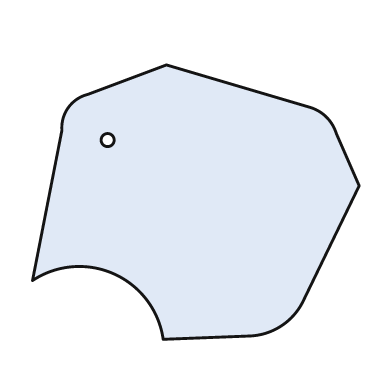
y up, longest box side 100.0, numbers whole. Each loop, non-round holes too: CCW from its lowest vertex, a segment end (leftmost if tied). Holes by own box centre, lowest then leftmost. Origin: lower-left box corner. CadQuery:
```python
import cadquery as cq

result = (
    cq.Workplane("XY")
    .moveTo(40.0, 0.0)
    .lineTo(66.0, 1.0)
    .threePointArc((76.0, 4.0), (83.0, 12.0))
    .lineTo(100.0, 47.0)
    .lineTo(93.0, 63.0)
    .threePointArc((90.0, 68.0), (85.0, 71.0))
    .lineTo(41.0, 84.0)
    .lineTo(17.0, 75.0)
    .threePointArc((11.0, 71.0), (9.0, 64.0))
    .lineTo(0.0, 18.0)
    .threePointArc((25.0, 20.0), (40.0, 0.0))
    .close()
    .moveTo(23.0, 61.0)
    .circle(2.0)
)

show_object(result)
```